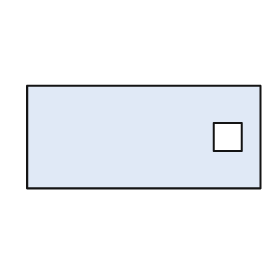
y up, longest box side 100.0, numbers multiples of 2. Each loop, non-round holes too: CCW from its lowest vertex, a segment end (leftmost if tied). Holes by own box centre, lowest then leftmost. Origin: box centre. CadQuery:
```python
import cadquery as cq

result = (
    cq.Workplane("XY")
    .moveTo(-50.0, -22.0)
    .lineTo(50.0, -22.0)
    .lineTo(50.0, 22.0)
    .lineTo(-50.0, 22.0)
    .close()
    .moveTo(30.0, -6.0)
    .lineTo(42.0, -6.0)
    .lineTo(42.0, 6.0)
    .lineTo(30.0, 6.0)
    .close()
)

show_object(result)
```